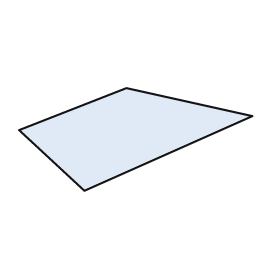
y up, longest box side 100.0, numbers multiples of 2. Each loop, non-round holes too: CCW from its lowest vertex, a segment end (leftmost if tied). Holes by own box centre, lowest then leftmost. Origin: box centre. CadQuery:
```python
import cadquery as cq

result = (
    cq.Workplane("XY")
    .moveTo(-22.0, -22.0)
    .lineTo(50.0, 10.0)
    .lineTo(-4.0, 22.0)
    .lineTo(-50.0, 4.0)
    .close()
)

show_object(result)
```